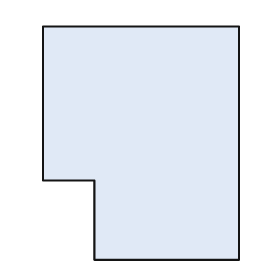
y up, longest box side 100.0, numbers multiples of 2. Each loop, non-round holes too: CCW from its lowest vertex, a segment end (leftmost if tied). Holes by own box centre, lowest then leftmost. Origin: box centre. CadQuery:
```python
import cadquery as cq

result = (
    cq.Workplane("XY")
    .moveTo(-20.0, -50.0)
    .lineTo(42.0, -50.0)
    .lineTo(42.0, 50.0)
    .lineTo(-42.0, 50.0)
    .lineTo(-42.0, -16.0)
    .lineTo(-20.0, -16.0)
    .close()
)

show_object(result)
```